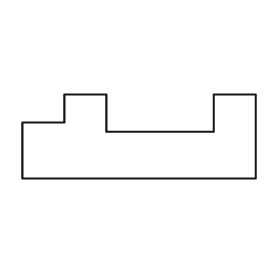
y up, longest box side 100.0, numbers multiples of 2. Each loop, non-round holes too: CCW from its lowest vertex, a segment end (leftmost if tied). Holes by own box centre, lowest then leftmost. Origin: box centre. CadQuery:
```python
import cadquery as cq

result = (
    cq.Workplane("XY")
    .moveTo(-50.0, -18.0)
    .lineTo(50.0, -18.0)
    .lineTo(50.0, 18.0)
    .lineTo(32.0, 18.0)
    .lineTo(32.0, 2.0)
    .lineTo(-14.0, 2.0)
    .lineTo(-14.0, 18.0)
    .lineTo(-32.0, 18.0)
    .lineTo(-32.0, 6.0)
    .lineTo(-50.0, 6.0)
    .close()
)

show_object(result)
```